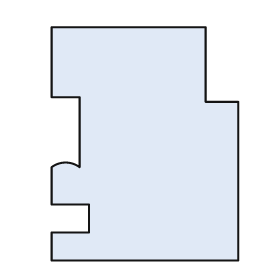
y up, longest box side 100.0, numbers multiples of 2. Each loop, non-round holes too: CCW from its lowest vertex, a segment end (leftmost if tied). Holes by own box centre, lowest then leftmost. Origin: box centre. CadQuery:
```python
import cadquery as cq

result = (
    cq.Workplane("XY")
    .moveTo(-40.0, -50.0)
    .lineTo(40.0, -50.0)
    .lineTo(40.0, 18.0)
    .lineTo(26.0, 18.0)
    .lineTo(26.0, 50.0)
    .lineTo(-40.0, 50.0)
    .lineTo(-40.0, 20.0)
    .lineTo(-28.0, 20.0)
    .lineTo(-28.0, -10.0)
    .threePointArc((-34.0, -8.0), (-40.0, -10.0))
    .lineTo(-40.0, -26.0)
    .lineTo(-24.0, -26.0)
    .lineTo(-24.0, -38.0)
    .lineTo(-40.0, -38.0)
    .close()
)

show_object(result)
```